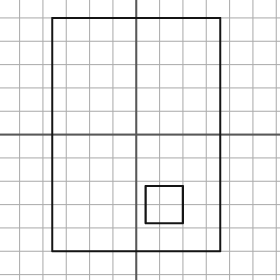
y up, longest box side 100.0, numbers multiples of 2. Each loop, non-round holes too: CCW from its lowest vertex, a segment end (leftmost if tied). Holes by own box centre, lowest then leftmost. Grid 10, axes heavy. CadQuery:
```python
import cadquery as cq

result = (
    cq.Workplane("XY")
    .moveTo(-36.0, -50.0)
    .lineTo(36.0, -50.0)
    .lineTo(36.0, 50.0)
    .lineTo(-36.0, 50.0)
    .close()
    .moveTo(4.0, -38.0)
    .lineTo(20.0, -38.0)
    .lineTo(20.0, -22.0)
    .lineTo(4.0, -22.0)
    .close()
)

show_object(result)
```